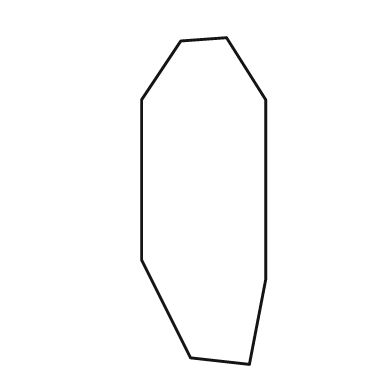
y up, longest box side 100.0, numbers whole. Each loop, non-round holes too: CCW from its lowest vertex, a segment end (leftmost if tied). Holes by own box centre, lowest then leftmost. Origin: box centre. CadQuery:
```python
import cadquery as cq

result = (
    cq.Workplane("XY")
    .moveTo(14.0, -50.0)
    .lineTo(19.0, -24.0)
    .lineTo(19.0, 31.0)
    .lineTo(7.0, 50.0)
    .lineTo(-7.0, 49.0)
    .lineTo(-19.0, 31.0)
    .lineTo(-19.0, -18.0)
    .lineTo(-4.0, -48.0)
    .close()
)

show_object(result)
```